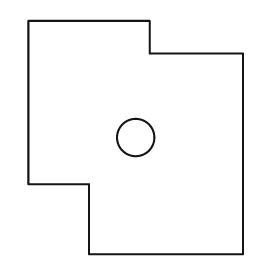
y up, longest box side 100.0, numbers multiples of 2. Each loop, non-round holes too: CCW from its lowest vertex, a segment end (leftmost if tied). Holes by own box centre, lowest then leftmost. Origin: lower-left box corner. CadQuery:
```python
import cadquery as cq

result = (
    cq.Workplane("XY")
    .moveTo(26.0, 0.0)
    .lineTo(92.0, 0.0)
    .lineTo(92.0, 86.0)
    .lineTo(52.0, 86.0)
    .lineTo(52.0, 100.0)
    .lineTo(0.0, 100.0)
    .lineTo(0.0, 30.0)
    .lineTo(26.0, 30.0)
    .close()
    .moveTo(46.0, 50.0)
    .circle(8.0)
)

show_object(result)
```